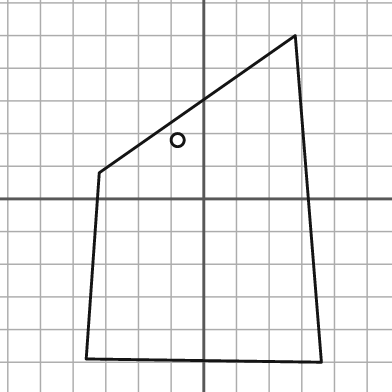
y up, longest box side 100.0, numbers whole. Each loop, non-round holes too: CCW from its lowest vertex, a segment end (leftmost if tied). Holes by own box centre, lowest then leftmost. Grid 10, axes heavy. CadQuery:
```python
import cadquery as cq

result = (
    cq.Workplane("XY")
    .moveTo(36.0, -50.0)
    .lineTo(28.0, 50.0)
    .lineTo(-32.0, 8.0)
    .lineTo(-36.0, -49.0)
    .close()
    .moveTo(-8.0, 18.0)
    .circle(2.0)
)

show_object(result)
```